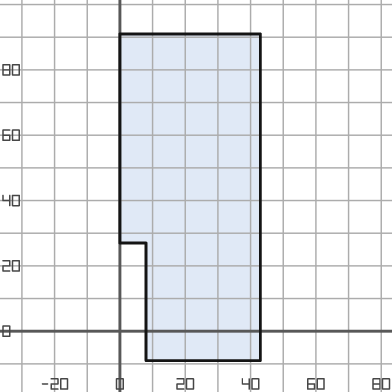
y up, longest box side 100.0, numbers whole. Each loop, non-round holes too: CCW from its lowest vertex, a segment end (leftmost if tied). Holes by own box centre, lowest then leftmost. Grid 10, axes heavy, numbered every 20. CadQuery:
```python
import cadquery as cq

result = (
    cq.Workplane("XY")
    .moveTo(8.0, -9.0)
    .lineTo(43.0, -9.0)
    .lineTo(43.0, 91.0)
    .lineTo(0.0, 91.0)
    .lineTo(0.0, 27.0)
    .lineTo(8.0, 27.0)
    .close()
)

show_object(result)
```